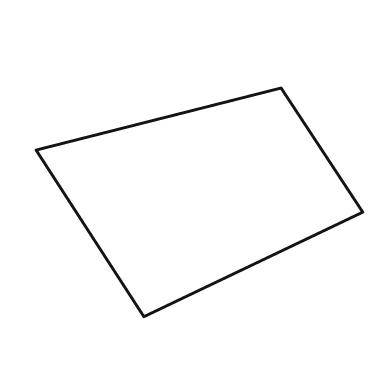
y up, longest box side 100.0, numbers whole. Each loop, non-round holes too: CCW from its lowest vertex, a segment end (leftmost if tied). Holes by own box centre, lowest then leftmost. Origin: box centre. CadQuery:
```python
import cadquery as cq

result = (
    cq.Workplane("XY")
    .moveTo(-17.0, -35.0)
    .lineTo(50.0, -3.0)
    .lineTo(25.0, 35.0)
    .lineTo(-50.0, 16.0)
    .close()
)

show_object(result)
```